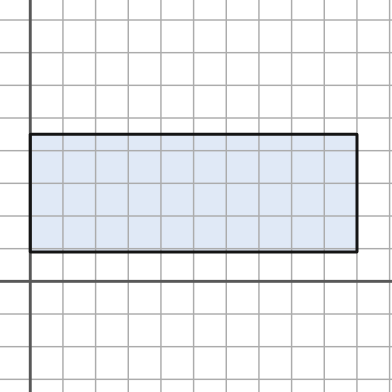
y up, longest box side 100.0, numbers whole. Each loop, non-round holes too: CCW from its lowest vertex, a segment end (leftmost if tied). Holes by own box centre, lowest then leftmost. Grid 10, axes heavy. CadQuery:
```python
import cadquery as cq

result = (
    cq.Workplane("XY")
    .moveTo(0.0, 9.0)
    .lineTo(100.0, 9.0)
    .lineTo(100.0, 45.0)
    .lineTo(0.0, 45.0)
    .close()
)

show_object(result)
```